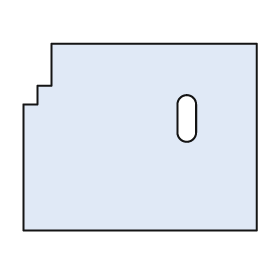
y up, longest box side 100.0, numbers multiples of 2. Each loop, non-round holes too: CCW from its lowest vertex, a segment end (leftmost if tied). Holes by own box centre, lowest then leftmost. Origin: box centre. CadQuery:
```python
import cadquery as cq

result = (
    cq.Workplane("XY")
    .moveTo(-50.0, -40.0)
    .lineTo(50.0, -40.0)
    .lineTo(50.0, 40.0)
    .lineTo(-38.0, 40.0)
    .lineTo(-38.0, 22.0)
    .lineTo(-44.0, 22.0)
    .lineTo(-44.0, 14.0)
    .lineTo(-50.0, 14.0)
    .close()
    .moveTo(16.0, 2.0)
    .threePointArc((20.0, -2.0), (24.0, 2.0))
    .lineTo(24.0, 14.0)
    .threePointArc((20.0, 18.0), (16.0, 14.0))
    .close()
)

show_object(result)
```